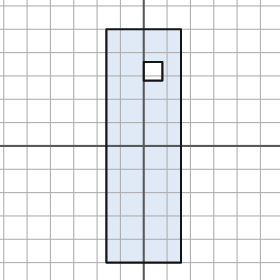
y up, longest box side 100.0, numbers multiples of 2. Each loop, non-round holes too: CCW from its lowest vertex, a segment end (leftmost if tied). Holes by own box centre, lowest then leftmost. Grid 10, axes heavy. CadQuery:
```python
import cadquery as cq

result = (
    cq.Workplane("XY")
    .moveTo(-16.0, -50.0)
    .lineTo(16.0, -50.0)
    .lineTo(16.0, 50.0)
    .lineTo(-16.0, 50.0)
    .close()
    .moveTo(0.0, 28.0)
    .lineTo(8.0, 28.0)
    .lineTo(8.0, 36.0)
    .lineTo(0.0, 36.0)
    .close()
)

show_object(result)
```